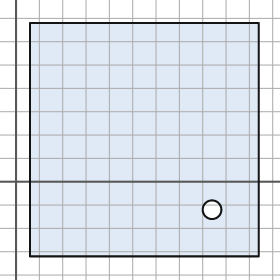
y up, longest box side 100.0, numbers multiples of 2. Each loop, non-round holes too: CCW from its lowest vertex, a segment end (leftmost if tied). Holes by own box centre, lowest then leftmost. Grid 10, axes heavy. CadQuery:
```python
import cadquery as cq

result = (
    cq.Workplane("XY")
    .moveTo(6.0, -32.0)
    .lineTo(104.0, -32.0)
    .lineTo(104.0, 68.0)
    .lineTo(6.0, 68.0)
    .close()
    .moveTo(84.0, -12.0)
    .circle(4.0)
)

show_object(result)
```